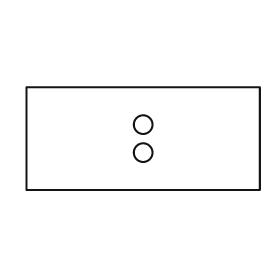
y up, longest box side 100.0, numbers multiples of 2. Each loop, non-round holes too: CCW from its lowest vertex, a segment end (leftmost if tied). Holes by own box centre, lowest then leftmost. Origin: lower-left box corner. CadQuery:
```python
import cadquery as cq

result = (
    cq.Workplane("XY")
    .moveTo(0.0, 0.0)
    .lineTo(100.0, 0.0)
    .lineTo(100.0, 44.0)
    .lineTo(0.0, 44.0)
    .close()
    .moveTo(50.0, 16.0)
    .circle(4.0)
    .moveTo(50.0, 28.0)
    .circle(4.0)
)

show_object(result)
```